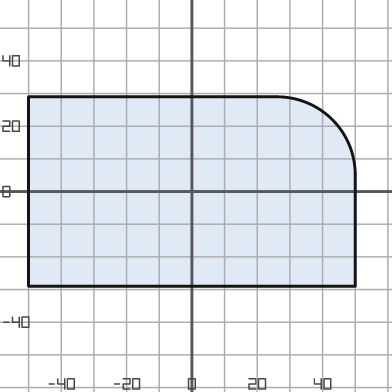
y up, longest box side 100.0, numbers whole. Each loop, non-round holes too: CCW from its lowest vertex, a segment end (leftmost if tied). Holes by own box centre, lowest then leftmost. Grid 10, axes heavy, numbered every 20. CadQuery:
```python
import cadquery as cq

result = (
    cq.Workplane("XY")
    .moveTo(-50.0, -29.0)
    .lineTo(50.0, -29.0)
    .lineTo(50.0, 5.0)
    .threePointArc((43.0, 22.0), (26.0, 29.0))
    .lineTo(-50.0, 29.0)
    .close()
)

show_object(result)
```